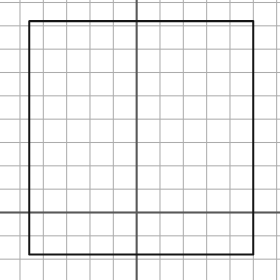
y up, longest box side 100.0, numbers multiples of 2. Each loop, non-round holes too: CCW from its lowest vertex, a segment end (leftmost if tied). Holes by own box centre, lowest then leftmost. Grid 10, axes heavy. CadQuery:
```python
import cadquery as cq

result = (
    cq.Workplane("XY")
    .moveTo(-46.0, -18.0)
    .lineTo(50.0, -18.0)
    .lineTo(50.0, 82.0)
    .lineTo(-46.0, 82.0)
    .close()
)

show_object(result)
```